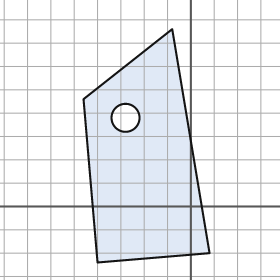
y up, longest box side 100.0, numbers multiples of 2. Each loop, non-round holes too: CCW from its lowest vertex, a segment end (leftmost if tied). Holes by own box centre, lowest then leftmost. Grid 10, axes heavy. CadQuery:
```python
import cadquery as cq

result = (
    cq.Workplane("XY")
    .moveTo(-40.0, -24.0)
    .lineTo(8.0, -20.0)
    .lineTo(-8.0, 76.0)
    .lineTo(-46.0, 46.0)
    .close()
    .moveTo(-28.0, 38.0)
    .circle(6.0)
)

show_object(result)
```